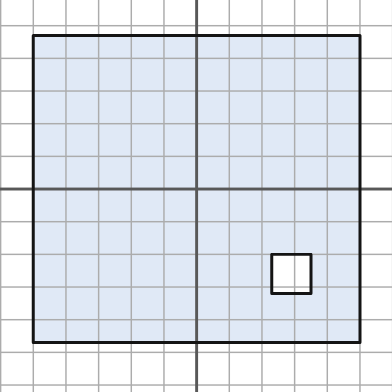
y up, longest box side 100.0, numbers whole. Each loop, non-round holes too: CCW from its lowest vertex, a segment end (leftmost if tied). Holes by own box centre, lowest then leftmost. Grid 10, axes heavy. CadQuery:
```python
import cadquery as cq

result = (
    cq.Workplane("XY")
    .moveTo(-50.0, -47.0)
    .lineTo(50.0, -47.0)
    .lineTo(50.0, 47.0)
    .lineTo(-50.0, 47.0)
    .close()
    .moveTo(23.0, -32.0)
    .lineTo(35.0, -32.0)
    .lineTo(35.0, -20.0)
    .lineTo(23.0, -20.0)
    .close()
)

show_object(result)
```